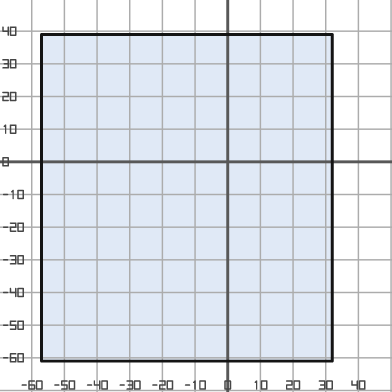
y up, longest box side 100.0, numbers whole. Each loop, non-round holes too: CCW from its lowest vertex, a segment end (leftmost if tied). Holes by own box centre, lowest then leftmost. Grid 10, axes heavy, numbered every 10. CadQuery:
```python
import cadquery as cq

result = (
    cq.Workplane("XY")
    .moveTo(-57.0, -61.0)
    .lineTo(32.0, -61.0)
    .lineTo(32.0, 39.0)
    .lineTo(-57.0, 39.0)
    .close()
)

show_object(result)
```